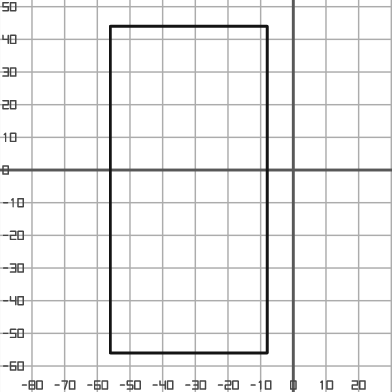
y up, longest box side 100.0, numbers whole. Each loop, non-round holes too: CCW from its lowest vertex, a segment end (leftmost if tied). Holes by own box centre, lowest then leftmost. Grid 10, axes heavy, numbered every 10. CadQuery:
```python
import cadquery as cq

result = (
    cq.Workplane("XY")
    .moveTo(-56.0, -56.0)
    .lineTo(-8.0, -56.0)
    .lineTo(-8.0, 44.0)
    .lineTo(-56.0, 44.0)
    .close()
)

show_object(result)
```